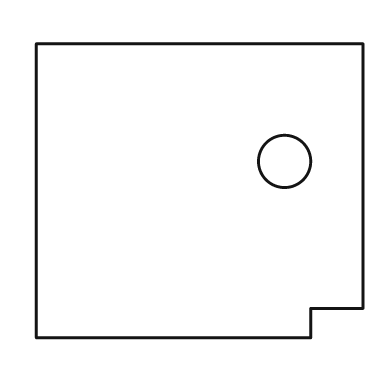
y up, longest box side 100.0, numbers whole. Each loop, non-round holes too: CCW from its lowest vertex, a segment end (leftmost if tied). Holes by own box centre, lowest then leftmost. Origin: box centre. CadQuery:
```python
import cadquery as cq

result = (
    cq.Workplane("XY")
    .moveTo(-50.0, -45.0)
    .lineTo(34.0, -45.0)
    .lineTo(34.0, -36.0)
    .lineTo(50.0, -36.0)
    .lineTo(50.0, 45.0)
    .lineTo(-50.0, 45.0)
    .close()
    .moveTo(26.0, 9.0)
    .circle(8.0)
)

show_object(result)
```